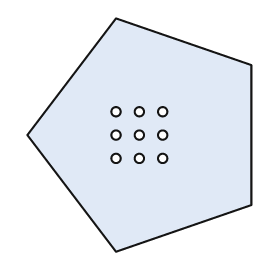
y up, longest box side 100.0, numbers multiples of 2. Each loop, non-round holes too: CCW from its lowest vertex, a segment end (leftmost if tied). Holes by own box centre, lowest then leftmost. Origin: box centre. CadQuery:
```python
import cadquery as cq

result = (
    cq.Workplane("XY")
    .moveTo(-10.0, -50.0)
    .lineTo(48.0, -30.0)
    .lineTo(48.0, 30.0)
    .lineTo(-10.0, 50.0)
    .lineTo(-48.0, 0.0)
    .close()
    .moveTo(-10.0, -10.0)
    .circle(2.0)
    .moveTo(0.0, -10.0)
    .circle(2.0)
    .moveTo(10.0, -10.0)
    .circle(2.0)
    .moveTo(-10.0, 0.0)
    .circle(2.0)
    .moveTo(0.0, 0.0)
    .circle(2.0)
    .moveTo(10.0, 0.0)
    .circle(2.0)
    .moveTo(-10.0, 10.0)
    .circle(2.0)
    .moveTo(0.0, 10.0)
    .circle(2.0)
    .moveTo(10.0, 10.0)
    .circle(2.0)
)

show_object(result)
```